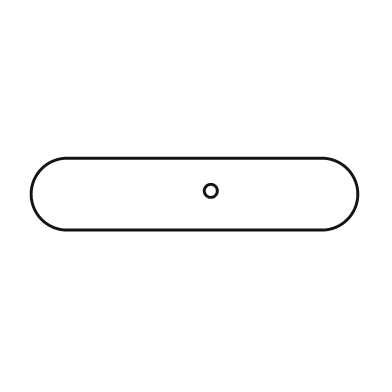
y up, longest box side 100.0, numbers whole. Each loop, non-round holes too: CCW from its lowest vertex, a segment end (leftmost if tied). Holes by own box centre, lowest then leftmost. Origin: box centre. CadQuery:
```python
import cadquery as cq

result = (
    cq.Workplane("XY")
    .moveTo(-39.0, -11.0)
    .lineTo(39.0, -11.0)
    .threePointArc((50.0, 0.0), (39.0, 11.0))
    .lineTo(-39.0, 11.0)
    .threePointArc((-50.0, 0.0), (-39.0, -11.0))
    .close()
    .moveTo(5.0, 1.0)
    .circle(2.0)
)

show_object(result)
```